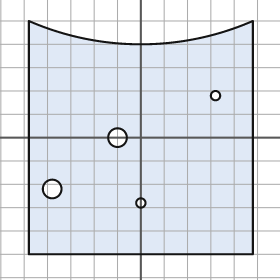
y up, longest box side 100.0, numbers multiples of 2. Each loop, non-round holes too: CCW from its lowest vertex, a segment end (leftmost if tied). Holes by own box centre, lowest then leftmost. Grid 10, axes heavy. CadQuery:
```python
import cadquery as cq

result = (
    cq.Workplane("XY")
    .moveTo(-48.0, -50.0)
    .lineTo(48.0, -50.0)
    .lineTo(48.0, 50.0)
    .threePointArc((0.0, 40.0), (-48.0, 50.0))
    .close()
    .moveTo(0.0, -28.0)
    .circle(2.0)
    .moveTo(-38.0, -22.0)
    .circle(4.0)
    .moveTo(-10.0, 0.0)
    .circle(4.0)
    .moveTo(32.0, 18.0)
    .circle(2.0)
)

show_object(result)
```